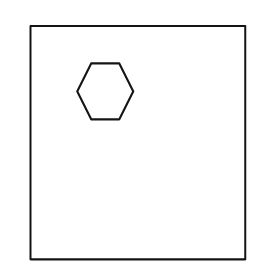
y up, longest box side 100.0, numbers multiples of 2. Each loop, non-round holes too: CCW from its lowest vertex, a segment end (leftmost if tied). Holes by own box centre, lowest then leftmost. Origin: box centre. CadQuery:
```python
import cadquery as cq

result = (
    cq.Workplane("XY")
    .moveTo(-46.0, -50.0)
    .lineTo(46.0, -50.0)
    .lineTo(46.0, 50.0)
    .lineTo(-46.0, 50.0)
    .close()
    .moveTo(-20.0, 10.0)
    .lineTo(-8.0, 10.0)
    .lineTo(-2.0, 22.0)
    .lineTo(-8.0, 34.0)
    .lineTo(-20.0, 34.0)
    .lineTo(-26.0, 22.0)
    .close()
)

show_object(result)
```